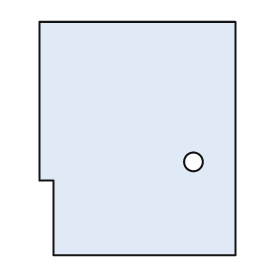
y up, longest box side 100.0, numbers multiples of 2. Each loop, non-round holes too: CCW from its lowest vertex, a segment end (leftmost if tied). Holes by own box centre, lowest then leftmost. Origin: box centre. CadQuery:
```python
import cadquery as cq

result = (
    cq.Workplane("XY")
    .moveTo(-36.0, -50.0)
    .lineTo(42.0, -50.0)
    .lineTo(42.0, 50.0)
    .lineTo(-42.0, 50.0)
    .lineTo(-42.0, -18.0)
    .lineTo(-36.0, -18.0)
    .close()
    .moveTo(24.0, -10.0)
    .circle(4.0)
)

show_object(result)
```